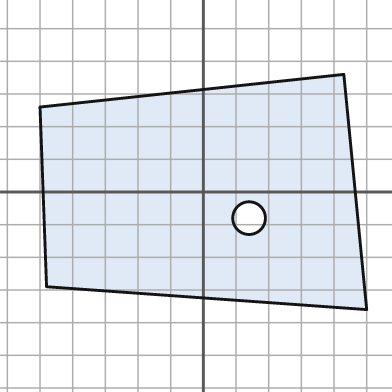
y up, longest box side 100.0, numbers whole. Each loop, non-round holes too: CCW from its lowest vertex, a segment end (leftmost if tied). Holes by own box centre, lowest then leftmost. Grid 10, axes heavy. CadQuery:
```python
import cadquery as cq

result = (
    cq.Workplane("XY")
    .moveTo(50.0, -36.0)
    .lineTo(43.0, 36.0)
    .lineTo(-50.0, 26.0)
    .lineTo(-48.0, -29.0)
    .close()
    .moveTo(14.0, -8.0)
    .circle(5.0)
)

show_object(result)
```